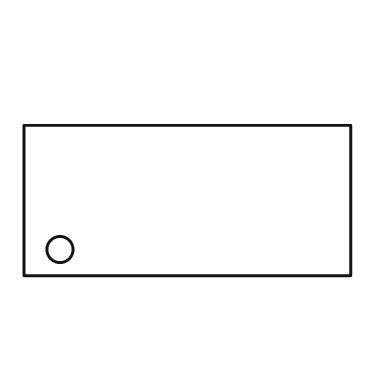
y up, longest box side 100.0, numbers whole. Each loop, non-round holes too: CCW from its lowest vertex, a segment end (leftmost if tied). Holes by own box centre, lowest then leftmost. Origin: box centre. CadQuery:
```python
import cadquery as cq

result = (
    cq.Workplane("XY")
    .moveTo(-50.0, -23.0)
    .lineTo(50.0, -23.0)
    .lineTo(50.0, 23.0)
    .lineTo(-50.0, 23.0)
    .close()
    .moveTo(-39.0, -15.0)
    .circle(4.0)
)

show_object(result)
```